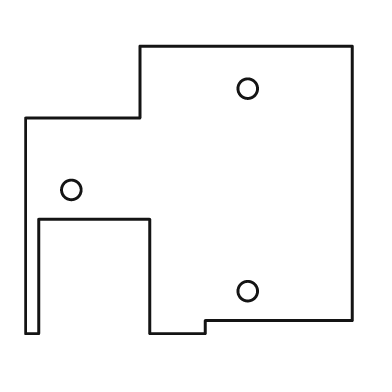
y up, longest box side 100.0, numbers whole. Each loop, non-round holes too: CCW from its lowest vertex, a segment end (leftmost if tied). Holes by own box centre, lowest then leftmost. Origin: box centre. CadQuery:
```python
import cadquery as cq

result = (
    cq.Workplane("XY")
    .moveTo(-50.0, -44.0)
    .lineTo(-46.0, -44.0)
    .lineTo(-46.0, -9.0)
    .lineTo(-12.0, -9.0)
    .lineTo(-12.0, -44.0)
    .lineTo(5.0, -44.0)
    .lineTo(5.0, -40.0)
    .lineTo(50.0, -40.0)
    .lineTo(50.0, 44.0)
    .lineTo(-15.0, 44.0)
    .lineTo(-15.0, 22.0)
    .lineTo(-50.0, 22.0)
    .close()
    .moveTo(18.0, -31.0)
    .circle(3.0)
    .moveTo(-36.0, 0.0)
    .circle(3.0)
    .moveTo(18.0, 31.0)
    .circle(3.0)
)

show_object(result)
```